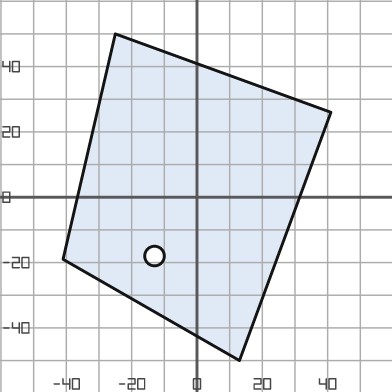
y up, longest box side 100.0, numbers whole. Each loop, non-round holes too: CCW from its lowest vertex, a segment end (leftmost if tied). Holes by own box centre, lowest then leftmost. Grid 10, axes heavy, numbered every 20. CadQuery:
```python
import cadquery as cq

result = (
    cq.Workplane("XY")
    .moveTo(13.0, -50.0)
    .lineTo(41.0, 26.0)
    .lineTo(-25.0, 50.0)
    .lineTo(-41.0, -19.0)
    .close()
    .moveTo(-13.0, -18.0)
    .circle(3.0)
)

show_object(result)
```